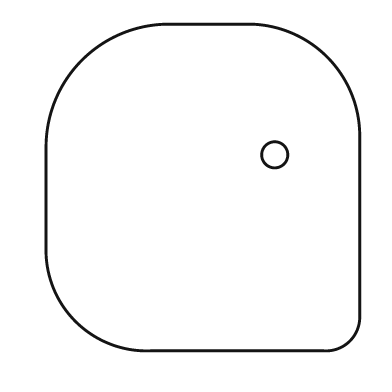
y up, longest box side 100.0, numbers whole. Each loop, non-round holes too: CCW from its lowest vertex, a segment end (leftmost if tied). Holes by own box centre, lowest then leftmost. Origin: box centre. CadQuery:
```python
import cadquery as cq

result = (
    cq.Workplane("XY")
    .moveTo(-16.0, -50.0)
    .lineTo(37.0, -50.0)
    .threePointArc((45.0, -47.0), (48.0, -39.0))
    .lineTo(48.0, 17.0)
    .threePointArc((38.0, 40.0), (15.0, 50.0))
    .lineTo(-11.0, 50.0)
    .threePointArc((-37.0, 39.0), (-48.0, 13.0))
    .lineTo(-48.0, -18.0)
    .threePointArc((-39.0, -41.0), (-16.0, -50.0))
    .close()
    .moveTo(22.0, 10.0)
    .circle(4.0)
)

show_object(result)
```